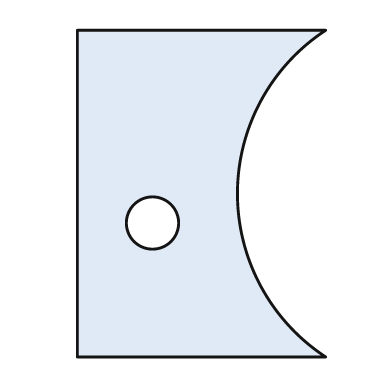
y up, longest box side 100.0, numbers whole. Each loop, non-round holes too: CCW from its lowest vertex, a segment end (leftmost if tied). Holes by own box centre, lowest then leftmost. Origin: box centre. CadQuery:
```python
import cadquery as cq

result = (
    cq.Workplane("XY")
    .moveTo(-38.0, -50.0)
    .lineTo(38.0, -50.0)
    .threePointArc((11.0, 0.0), (38.0, 50.0))
    .lineTo(-38.0, 50.0)
    .close()
    .moveTo(-15.0, -9.0)
    .circle(8.0)
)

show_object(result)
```